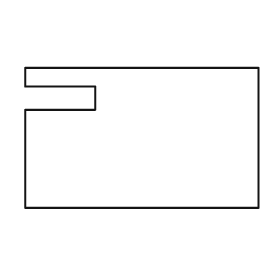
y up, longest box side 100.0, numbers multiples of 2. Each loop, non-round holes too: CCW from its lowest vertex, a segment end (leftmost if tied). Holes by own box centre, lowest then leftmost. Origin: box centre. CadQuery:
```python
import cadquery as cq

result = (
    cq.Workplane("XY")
    .moveTo(-50.0, -30.0)
    .lineTo(50.0, -30.0)
    .lineTo(50.0, 30.0)
    .lineTo(-50.0, 30.0)
    .lineTo(-50.0, 22.0)
    .lineTo(-20.0, 22.0)
    .lineTo(-20.0, 12.0)
    .lineTo(-50.0, 12.0)
    .close()
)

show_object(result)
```